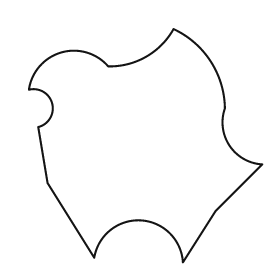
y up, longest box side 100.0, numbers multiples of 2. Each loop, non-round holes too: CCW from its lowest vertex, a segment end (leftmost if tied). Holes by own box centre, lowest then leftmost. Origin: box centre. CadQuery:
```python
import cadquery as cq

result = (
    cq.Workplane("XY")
    .moveTo(16.0, -50.0)
    .lineTo(30.0, -28.0)
    .lineTo(50.0, -8.0)
    .threePointArc((36.0, 0.0), (34.0, 16.0))
    .threePointArc((28.0, 36.0), (12.0, 50.0))
    .threePointArc((0.0, 38.0), (-16.0, 34.0))
    .threePointArc((-36.0, 40.0), (-50.0, 24.0))
    .threePointArc((-40.0, 18.0), (-46.0, 8.0))
    .lineTo(-42.0, -16.0)
    .lineTo(-22.0, -48.0)
    .threePointArc((-2.0, -32.0), (16.0, -50.0))
    .close()
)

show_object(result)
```